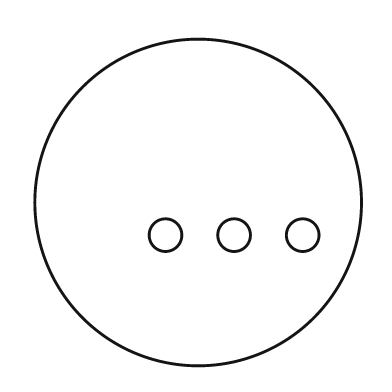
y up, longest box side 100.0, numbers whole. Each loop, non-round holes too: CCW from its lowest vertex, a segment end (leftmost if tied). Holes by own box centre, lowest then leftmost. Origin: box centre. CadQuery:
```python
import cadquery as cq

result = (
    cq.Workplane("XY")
    .moveTo(0.0, 0.0)
    .circle(50.0)
    .moveTo(-10.0, -10.0)
    .circle(5.0)
    .moveTo(11.0, -10.0)
    .circle(5.0)
    .moveTo(32.0, -10.0)
    .circle(5.0)
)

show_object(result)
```